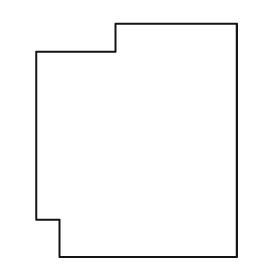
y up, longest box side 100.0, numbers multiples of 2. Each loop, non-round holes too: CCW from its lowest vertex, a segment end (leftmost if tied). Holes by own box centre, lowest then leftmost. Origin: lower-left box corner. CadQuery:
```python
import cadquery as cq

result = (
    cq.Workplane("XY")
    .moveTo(10.0, 0.0)
    .lineTo(86.0, 0.0)
    .lineTo(86.0, 100.0)
    .lineTo(34.0, 100.0)
    .lineTo(34.0, 88.0)
    .lineTo(0.0, 88.0)
    .lineTo(0.0, 16.0)
    .lineTo(10.0, 16.0)
    .close()
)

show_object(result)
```